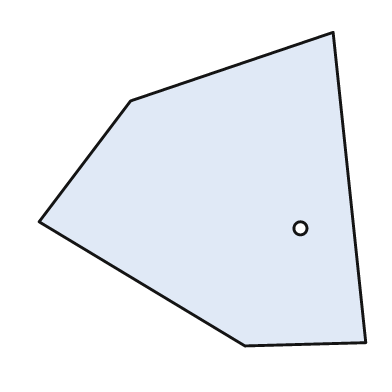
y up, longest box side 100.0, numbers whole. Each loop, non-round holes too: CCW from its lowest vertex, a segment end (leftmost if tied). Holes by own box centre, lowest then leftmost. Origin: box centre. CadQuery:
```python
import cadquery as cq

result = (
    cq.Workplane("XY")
    .moveTo(13.0, -48.0)
    .lineTo(50.0, -47.0)
    .lineTo(40.0, 48.0)
    .lineTo(-22.0, 27.0)
    .lineTo(-50.0, -10.0)
    .close()
    .moveTo(30.0, -12.0)
    .circle(2.0)
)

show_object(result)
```